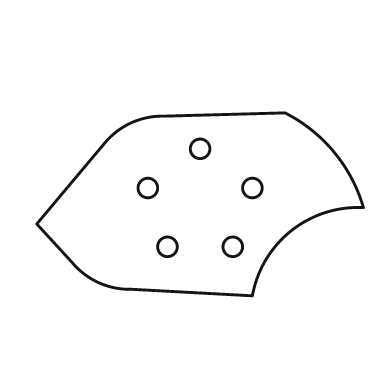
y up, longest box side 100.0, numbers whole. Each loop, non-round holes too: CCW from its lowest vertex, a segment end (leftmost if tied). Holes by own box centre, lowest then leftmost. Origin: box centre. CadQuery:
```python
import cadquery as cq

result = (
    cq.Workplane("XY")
    .moveTo(16.0, -28.0)
    .threePointArc((28.0, -8.0), (50.0, -1.0))
    .threePointArc((41.0, 16.0), (26.0, 28.0))
    .lineTo(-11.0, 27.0)
    .threePointArc((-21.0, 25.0), (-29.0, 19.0))
    .lineTo(-50.0, -6.0)
    .lineTo(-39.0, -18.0)
    .threePointArc((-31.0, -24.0), (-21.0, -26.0))
    .close()
    .moveTo(-10.0, -13.0)
    .circle(3.0)
    .moveTo(10.0, -13.0)
    .circle(3.0)
    .moveTo(-16.0, 5.0)
    .circle(3.0)
    .moveTo(16.0, 5.0)
    .circle(3.0)
    .moveTo(0.0, 17.0)
    .circle(3.0)
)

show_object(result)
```